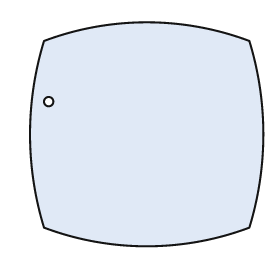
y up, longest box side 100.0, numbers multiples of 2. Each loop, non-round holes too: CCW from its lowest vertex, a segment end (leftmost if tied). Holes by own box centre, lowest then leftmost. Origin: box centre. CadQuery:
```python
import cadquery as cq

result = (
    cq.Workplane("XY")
    .moveTo(-44.0, -40.0)
    .threePointArc((0.0, -48.0), (44.0, -40.0))
    .threePointArc((50.0, 0.0), (44.0, 40.0))
    .threePointArc((0.0, 48.0), (-44.0, 40.0))
    .threePointArc((-50.0, 0.0), (-44.0, -40.0))
    .close()
    .moveTo(-42.0, 14.0)
    .circle(2.0)
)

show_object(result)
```